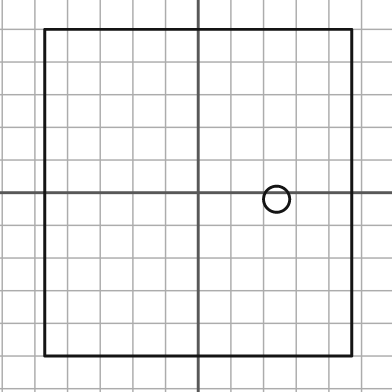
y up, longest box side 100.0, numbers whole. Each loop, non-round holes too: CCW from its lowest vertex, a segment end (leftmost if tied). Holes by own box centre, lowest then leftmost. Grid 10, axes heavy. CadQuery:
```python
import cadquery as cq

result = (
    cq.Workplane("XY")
    .moveTo(-47.0, -50.0)
    .lineTo(47.0, -50.0)
    .lineTo(47.0, 50.0)
    .lineTo(-47.0, 50.0)
    .close()
    .moveTo(24.0, -2.0)
    .circle(4.0)
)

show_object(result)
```